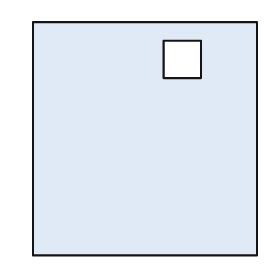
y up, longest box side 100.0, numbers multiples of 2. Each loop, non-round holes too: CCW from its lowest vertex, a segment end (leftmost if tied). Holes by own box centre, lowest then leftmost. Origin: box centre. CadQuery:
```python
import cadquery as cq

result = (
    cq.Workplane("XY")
    .moveTo(-48.0, -50.0)
    .lineTo(48.0, -50.0)
    .lineTo(48.0, 50.0)
    .lineTo(-48.0, 50.0)
    .close()
    .moveTo(8.0, 26.0)
    .lineTo(24.0, 26.0)
    .lineTo(24.0, 42.0)
    .lineTo(8.0, 42.0)
    .close()
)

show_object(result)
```